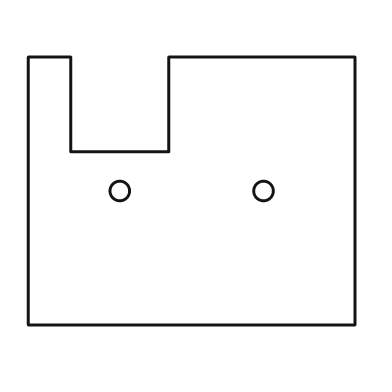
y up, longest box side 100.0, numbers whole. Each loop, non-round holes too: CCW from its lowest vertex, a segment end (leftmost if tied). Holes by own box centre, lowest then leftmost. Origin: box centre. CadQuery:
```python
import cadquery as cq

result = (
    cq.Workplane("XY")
    .moveTo(-50.0, -41.0)
    .lineTo(50.0, -41.0)
    .lineTo(50.0, 41.0)
    .lineTo(-7.0, 41.0)
    .lineTo(-7.0, 12.0)
    .lineTo(-37.0, 12.0)
    .lineTo(-37.0, 41.0)
    .lineTo(-50.0, 41.0)
    .close()
    .moveTo(-22.0, 0.0)
    .circle(3.0)
    .moveTo(22.0, 0.0)
    .circle(3.0)
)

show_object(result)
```